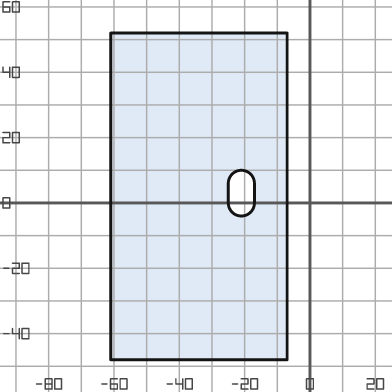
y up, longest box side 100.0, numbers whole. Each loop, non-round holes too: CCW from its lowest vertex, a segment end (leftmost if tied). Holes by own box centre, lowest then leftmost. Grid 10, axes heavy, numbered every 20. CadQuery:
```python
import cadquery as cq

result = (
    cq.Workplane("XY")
    .moveTo(-61.0, -48.0)
    .lineTo(-7.0, -48.0)
    .lineTo(-7.0, 52.0)
    .lineTo(-61.0, 52.0)
    .close()
    .moveTo(-25.0, 0.0)
    .threePointArc((-21.0, -4.0), (-17.0, 0.0))
    .lineTo(-17.0, 6.0)
    .threePointArc((-21.0, 10.0), (-25.0, 6.0))
    .close()
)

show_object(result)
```